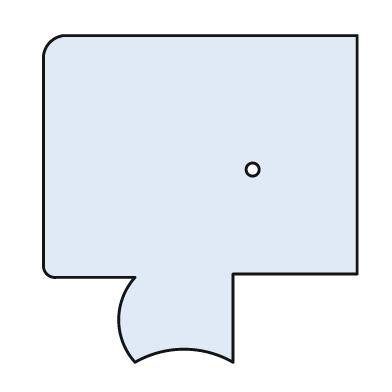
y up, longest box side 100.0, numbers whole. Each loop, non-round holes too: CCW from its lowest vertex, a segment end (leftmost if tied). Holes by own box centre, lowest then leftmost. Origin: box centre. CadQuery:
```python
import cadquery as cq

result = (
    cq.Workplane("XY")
    .moveTo(-20.0, -50.0)
    .threePointArc((-5.0, -46.0), (10.0, -50.0))
    .lineTo(10.0, -23.0)
    .lineTo(48.0, -23.0)
    .lineTo(48.0, 50.0)
    .lineTo(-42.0, 50.0)
    .threePointArc((-46.0, 48.0), (-48.0, 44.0))
    .lineTo(-48.0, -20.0)
    .threePointArc((-47.0, -23.0), (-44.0, -24.0))
    .lineTo(-20.0, -24.0)
    .threePointArc((-25.0, -37.0), (-20.0, -50.0))
    .close()
    .moveTo(16.0, 9.0)
    .circle(2.0)
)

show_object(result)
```